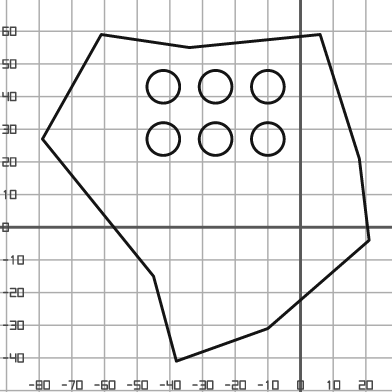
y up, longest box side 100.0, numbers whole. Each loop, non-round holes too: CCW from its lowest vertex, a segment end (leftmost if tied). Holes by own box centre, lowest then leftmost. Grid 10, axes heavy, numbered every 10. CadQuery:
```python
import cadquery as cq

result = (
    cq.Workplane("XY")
    .moveTo(-38.0, -41.0)
    .lineTo(-10.0, -31.0)
    .lineTo(21.0, -4.0)
    .lineTo(18.0, 21.0)
    .lineTo(6.0, 59.0)
    .lineTo(-34.0, 55.0)
    .lineTo(-61.0, 59.0)
    .lineTo(-79.0, 27.0)
    .lineTo(-45.0, -15.0)
    .close()
    .moveTo(-42.0, 27.0)
    .circle(5.0)
    .moveTo(-26.0, 27.0)
    .circle(5.0)
    .moveTo(-10.0, 27.0)
    .circle(5.0)
    .moveTo(-42.0, 43.0)
    .circle(5.0)
    .moveTo(-26.0, 43.0)
    .circle(5.0)
    .moveTo(-10.0, 43.0)
    .circle(5.0)
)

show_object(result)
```